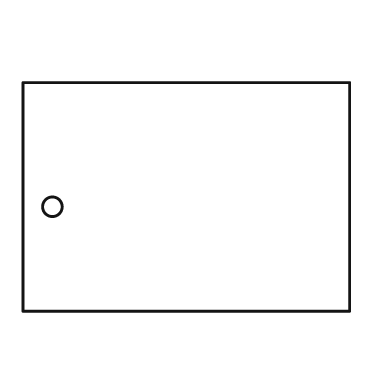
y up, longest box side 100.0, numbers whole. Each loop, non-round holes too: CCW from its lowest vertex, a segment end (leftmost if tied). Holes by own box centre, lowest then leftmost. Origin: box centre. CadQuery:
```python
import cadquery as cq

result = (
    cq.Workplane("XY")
    .moveTo(-50.0, -35.0)
    .lineTo(50.0, -35.0)
    .lineTo(50.0, 35.0)
    .lineTo(-50.0, 35.0)
    .close()
    .moveTo(-41.0, -3.0)
    .circle(3.0)
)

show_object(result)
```